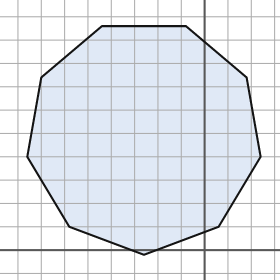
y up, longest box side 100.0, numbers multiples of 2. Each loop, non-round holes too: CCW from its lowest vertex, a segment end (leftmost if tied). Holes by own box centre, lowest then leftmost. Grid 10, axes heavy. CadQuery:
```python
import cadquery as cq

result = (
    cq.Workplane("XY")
    .moveTo(-26.0, -2.0)
    .lineTo(6.0, 10.0)
    .lineTo(24.0, 40.0)
    .lineTo(18.0, 74.0)
    .lineTo(-8.0, 96.0)
    .lineTo(-44.0, 96.0)
    .lineTo(-70.0, 74.0)
    .lineTo(-76.0, 40.0)
    .lineTo(-58.0, 10.0)
    .close()
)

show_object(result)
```